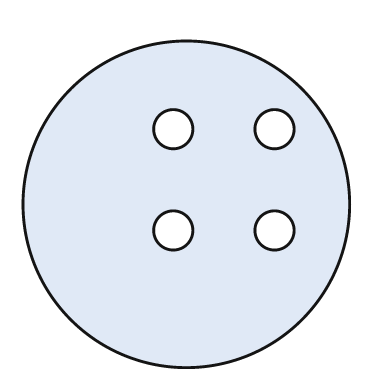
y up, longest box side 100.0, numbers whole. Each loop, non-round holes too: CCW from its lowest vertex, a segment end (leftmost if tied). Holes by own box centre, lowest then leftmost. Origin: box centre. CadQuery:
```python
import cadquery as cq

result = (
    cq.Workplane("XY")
    .moveTo(0.0, 0.0)
    .circle(50.0)
    .moveTo(-4.0, -8.0)
    .circle(6.0)
    .moveTo(27.0, -8.0)
    .circle(6.0)
    .moveTo(-4.0, 23.0)
    .circle(6.0)
    .moveTo(27.0, 23.0)
    .circle(6.0)
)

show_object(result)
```